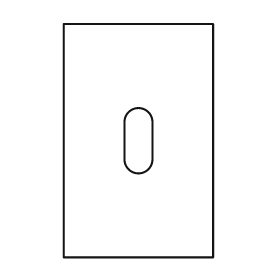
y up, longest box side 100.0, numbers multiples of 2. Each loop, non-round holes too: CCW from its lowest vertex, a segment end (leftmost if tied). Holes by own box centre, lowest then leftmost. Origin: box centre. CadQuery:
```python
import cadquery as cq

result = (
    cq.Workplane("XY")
    .moveTo(-32.0, -50.0)
    .lineTo(32.0, -50.0)
    .lineTo(32.0, 50.0)
    .lineTo(-32.0, 50.0)
    .close()
    .moveTo(-6.0, -8.0)
    .threePointArc((0.0, -14.0), (6.0, -8.0))
    .lineTo(6.0, 8.0)
    .threePointArc((0.0, 14.0), (-6.0, 8.0))
    .close()
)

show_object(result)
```